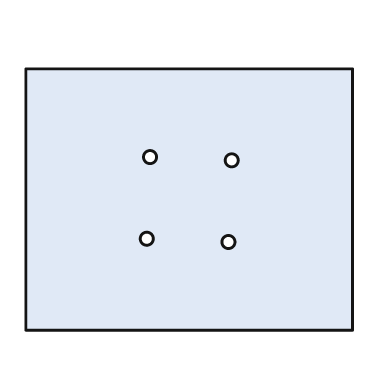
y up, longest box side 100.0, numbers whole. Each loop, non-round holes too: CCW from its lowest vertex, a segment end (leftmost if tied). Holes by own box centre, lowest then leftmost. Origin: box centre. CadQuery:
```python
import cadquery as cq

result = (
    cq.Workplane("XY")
    .moveTo(-50.0, -40.0)
    .lineTo(50.0, -40.0)
    .lineTo(50.0, 40.0)
    .lineTo(-50.0, 40.0)
    .close()
    .moveTo(12.0, -13.0)
    .circle(2.0)
    .moveTo(-13.0, -12.0)
    .circle(2.0)
    .moveTo(13.0, 12.0)
    .circle(2.0)
    .moveTo(-12.0, 13.0)
    .circle(2.0)
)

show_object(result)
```